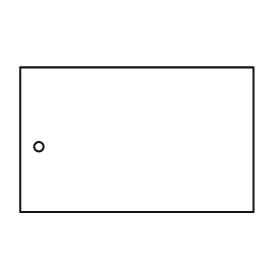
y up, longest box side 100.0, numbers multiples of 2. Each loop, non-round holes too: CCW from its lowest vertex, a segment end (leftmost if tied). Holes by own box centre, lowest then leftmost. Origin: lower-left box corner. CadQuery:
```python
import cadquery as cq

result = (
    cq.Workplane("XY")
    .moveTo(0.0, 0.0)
    .lineTo(100.0, 0.0)
    .lineTo(100.0, 62.0)
    .lineTo(0.0, 62.0)
    .close()
    .moveTo(8.0, 28.0)
    .circle(2.0)
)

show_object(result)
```